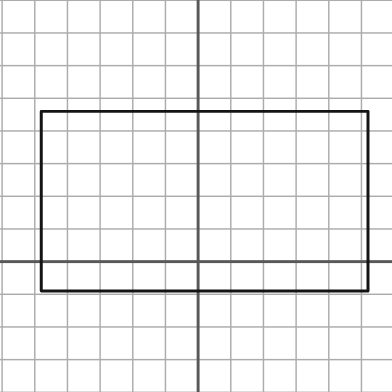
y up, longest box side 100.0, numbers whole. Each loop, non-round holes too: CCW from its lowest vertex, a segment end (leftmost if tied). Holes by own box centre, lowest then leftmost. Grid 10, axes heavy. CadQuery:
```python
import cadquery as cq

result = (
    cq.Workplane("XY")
    .moveTo(-48.0, -9.0)
    .lineTo(52.0, -9.0)
    .lineTo(52.0, 46.0)
    .lineTo(-48.0, 46.0)
    .close()
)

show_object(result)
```